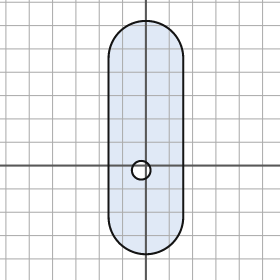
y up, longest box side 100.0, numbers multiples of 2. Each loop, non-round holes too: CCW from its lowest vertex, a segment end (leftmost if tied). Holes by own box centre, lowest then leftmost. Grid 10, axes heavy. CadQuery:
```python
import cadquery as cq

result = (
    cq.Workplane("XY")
    .moveTo(-16.0, -22.0)
    .threePointArc((0.0, -38.0), (16.0, -22.0))
    .lineTo(16.0, 46.0)
    .threePointArc((0.0, 62.0), (-16.0, 46.0))
    .close()
    .moveTo(-2.0, -2.0)
    .circle(4.0)
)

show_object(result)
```